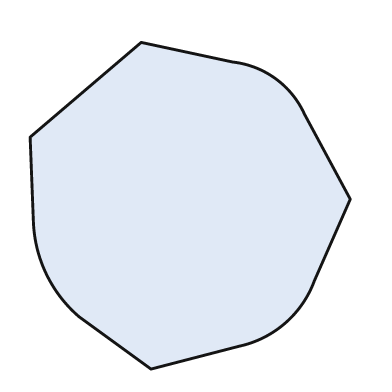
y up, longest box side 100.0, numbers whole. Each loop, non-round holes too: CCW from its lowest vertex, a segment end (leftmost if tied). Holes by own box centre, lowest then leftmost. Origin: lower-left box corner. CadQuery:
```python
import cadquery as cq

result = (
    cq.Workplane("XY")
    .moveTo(37.0, 0.0)
    .lineTo(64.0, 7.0)
    .threePointArc((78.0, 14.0), (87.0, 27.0))
    .lineTo(98.0, 52.0)
    .lineTo(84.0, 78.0)
    .threePointArc((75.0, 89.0), (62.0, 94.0))
    .lineTo(34.0, 100.0)
    .lineTo(0.0, 71.0)
    .lineTo(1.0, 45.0)
    .threePointArc((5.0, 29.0), (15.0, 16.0))
    .close()
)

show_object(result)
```